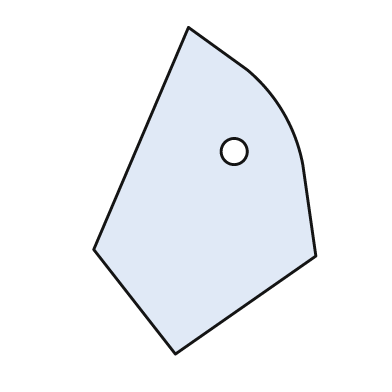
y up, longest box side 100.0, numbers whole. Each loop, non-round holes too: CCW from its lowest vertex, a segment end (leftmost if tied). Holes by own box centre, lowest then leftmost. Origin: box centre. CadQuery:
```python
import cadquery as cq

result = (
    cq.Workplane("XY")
    .moveTo(-9.0, -50.0)
    .lineTo(34.0, -20.0)
    .lineTo(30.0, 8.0)
    .threePointArc((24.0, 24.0), (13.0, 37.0))
    .lineTo(-5.0, 50.0)
    .lineTo(-34.0, -18.0)
    .close()
    .moveTo(9.0, 12.0)
    .circle(4.0)
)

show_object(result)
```